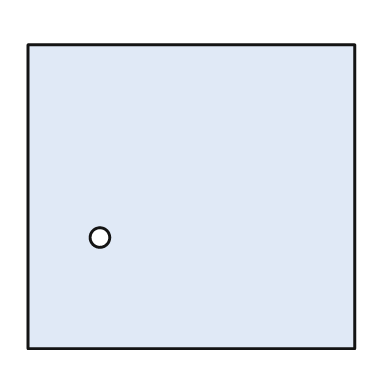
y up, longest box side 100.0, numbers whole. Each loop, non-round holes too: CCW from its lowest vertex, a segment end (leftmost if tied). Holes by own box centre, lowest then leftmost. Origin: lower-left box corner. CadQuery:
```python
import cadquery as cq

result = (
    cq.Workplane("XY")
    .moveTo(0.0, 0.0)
    .lineTo(100.0, 0.0)
    .lineTo(100.0, 93.0)
    .lineTo(0.0, 93.0)
    .close()
    .moveTo(22.0, 34.0)
    .circle(3.0)
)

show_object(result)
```